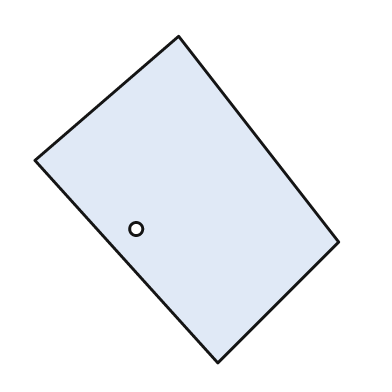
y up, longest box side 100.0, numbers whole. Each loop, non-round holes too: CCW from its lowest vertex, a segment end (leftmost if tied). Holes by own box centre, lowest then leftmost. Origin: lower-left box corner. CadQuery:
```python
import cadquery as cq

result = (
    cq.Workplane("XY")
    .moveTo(56.0, 0.0)
    .lineTo(93.0, 37.0)
    .lineTo(44.0, 100.0)
    .lineTo(0.0, 62.0)
    .close()
    .moveTo(31.0, 41.0)
    .circle(2.0)
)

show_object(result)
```